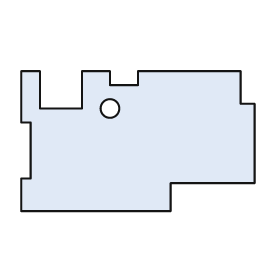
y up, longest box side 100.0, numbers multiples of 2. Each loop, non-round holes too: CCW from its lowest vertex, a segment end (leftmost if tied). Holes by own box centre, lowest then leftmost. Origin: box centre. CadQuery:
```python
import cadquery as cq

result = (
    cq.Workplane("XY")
    .moveTo(-50.0, -30.0)
    .lineTo(14.0, -30.0)
    .lineTo(14.0, -18.0)
    .lineTo(50.0, -18.0)
    .lineTo(50.0, 16.0)
    .lineTo(44.0, 16.0)
    .lineTo(44.0, 30.0)
    .lineTo(0.0, 30.0)
    .lineTo(0.0, 24.0)
    .lineTo(-12.0, 24.0)
    .lineTo(-12.0, 30.0)
    .lineTo(-24.0, 30.0)
    .lineTo(-24.0, 14.0)
    .lineTo(-42.0, 14.0)
    .lineTo(-42.0, 30.0)
    .lineTo(-50.0, 30.0)
    .lineTo(-50.0, 8.0)
    .lineTo(-46.0, 8.0)
    .lineTo(-46.0, -16.0)
    .lineTo(-50.0, -16.0)
    .close()
    .moveTo(-12.0, 14.0)
    .circle(4.0)
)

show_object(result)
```